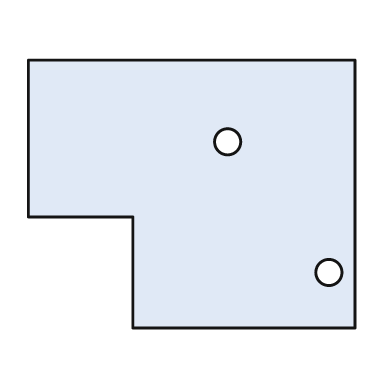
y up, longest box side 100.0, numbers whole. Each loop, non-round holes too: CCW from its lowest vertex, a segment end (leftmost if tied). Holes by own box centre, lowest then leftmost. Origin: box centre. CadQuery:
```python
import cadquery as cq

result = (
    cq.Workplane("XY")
    .moveTo(-18.0, -41.0)
    .lineTo(50.0, -41.0)
    .lineTo(50.0, 41.0)
    .lineTo(-50.0, 41.0)
    .lineTo(-50.0, -7.0)
    .lineTo(-18.0, -7.0)
    .close()
    .moveTo(42.0, -24.0)
    .circle(4.0)
    .moveTo(11.0, 16.0)
    .circle(4.0)
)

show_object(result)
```